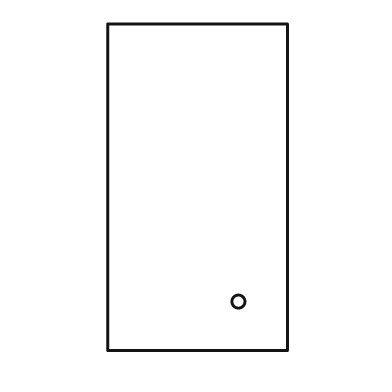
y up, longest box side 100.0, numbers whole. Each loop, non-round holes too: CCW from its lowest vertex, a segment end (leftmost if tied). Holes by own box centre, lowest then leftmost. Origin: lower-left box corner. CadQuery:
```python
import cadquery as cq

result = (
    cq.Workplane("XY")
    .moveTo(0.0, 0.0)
    .lineTo(55.0, 0.0)
    .lineTo(55.0, 100.0)
    .lineTo(0.0, 100.0)
    .close()
    .moveTo(40.0, 15.0)
    .circle(2.0)
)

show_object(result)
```